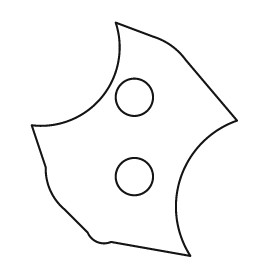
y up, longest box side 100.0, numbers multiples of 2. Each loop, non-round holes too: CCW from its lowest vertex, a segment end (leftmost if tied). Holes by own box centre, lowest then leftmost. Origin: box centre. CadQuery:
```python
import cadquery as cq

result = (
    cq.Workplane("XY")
    .moveTo(24.0, -50.0)
    .threePointArc((20.0, -16.0), (44.0, 8.0))
    .lineTo(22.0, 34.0)
    .threePointArc((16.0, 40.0), (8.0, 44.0))
    .lineTo(-8.0, 50.0)
    .threePointArc((-14.0, 18.0), (-44.0, 6.0))
    .lineTo(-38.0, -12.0)
    .threePointArc((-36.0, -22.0), (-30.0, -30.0))
    .lineTo(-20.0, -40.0)
    .threePointArc((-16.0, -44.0), (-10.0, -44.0))
    .close()
    .moveTo(0.0, -16.0)
    .circle(8.0)
    .moveTo(0.0, 18.0)
    .circle(8.0)
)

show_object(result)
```